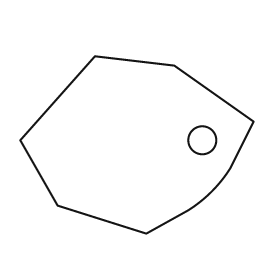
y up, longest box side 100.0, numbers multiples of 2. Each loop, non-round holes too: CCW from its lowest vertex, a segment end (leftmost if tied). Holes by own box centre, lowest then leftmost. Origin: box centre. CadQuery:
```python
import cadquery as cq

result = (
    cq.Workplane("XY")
    .moveTo(4.0, -38.0)
    .lineTo(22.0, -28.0)
    .threePointArc((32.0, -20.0), (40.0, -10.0))
    .lineTo(50.0, 10.0)
    .lineTo(16.0, 34.0)
    .lineTo(-18.0, 38.0)
    .lineTo(-50.0, 2.0)
    .lineTo(-34.0, -26.0)
    .close()
    .moveTo(28.0, 2.0)
    .circle(6.0)
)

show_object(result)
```